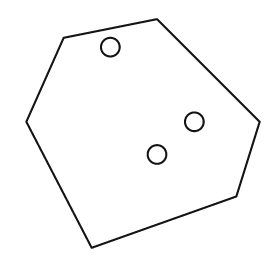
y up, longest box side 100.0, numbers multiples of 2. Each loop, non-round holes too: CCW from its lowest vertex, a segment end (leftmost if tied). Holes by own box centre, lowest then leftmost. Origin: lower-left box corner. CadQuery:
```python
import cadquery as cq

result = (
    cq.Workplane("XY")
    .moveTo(28.0, 0.0)
    .lineTo(90.0, 22.0)
    .lineTo(100.0, 54.0)
    .lineTo(56.0, 98.0)
    .lineTo(16.0, 90.0)
    .lineTo(0.0, 54.0)
    .close()
    .moveTo(56.0, 40.0)
    .circle(4.0)
    .moveTo(72.0, 54.0)
    .circle(4.0)
    .moveTo(36.0, 86.0)
    .circle(4.0)
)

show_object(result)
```